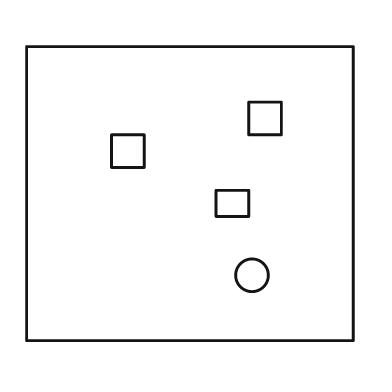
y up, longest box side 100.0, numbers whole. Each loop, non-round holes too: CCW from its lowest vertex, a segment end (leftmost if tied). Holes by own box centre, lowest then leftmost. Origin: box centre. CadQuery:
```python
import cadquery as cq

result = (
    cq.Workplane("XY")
    .moveTo(-50.0, -45.0)
    .lineTo(50.0, -45.0)
    .lineTo(50.0, 45.0)
    .lineTo(-50.0, 45.0)
    .close()
    .moveTo(19.0, -25.0)
    .circle(5.0)
    .moveTo(8.0, -7.0)
    .lineTo(18.0, -7.0)
    .lineTo(18.0, 1.0)
    .lineTo(8.0, 1.0)
    .close()
    .moveTo(-24.0, 8.0)
    .lineTo(-14.0, 8.0)
    .lineTo(-14.0, 18.0)
    .lineTo(-24.0, 18.0)
    .close()
    .moveTo(18.0, 18.0)
    .lineTo(28.0, 18.0)
    .lineTo(28.0, 28.0)
    .lineTo(18.0, 28.0)
    .close()
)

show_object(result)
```